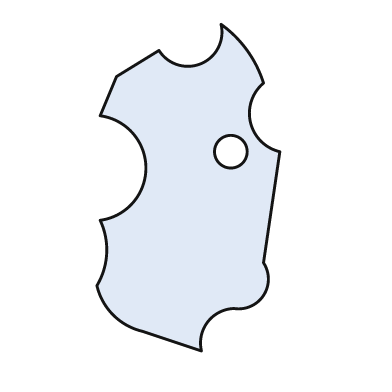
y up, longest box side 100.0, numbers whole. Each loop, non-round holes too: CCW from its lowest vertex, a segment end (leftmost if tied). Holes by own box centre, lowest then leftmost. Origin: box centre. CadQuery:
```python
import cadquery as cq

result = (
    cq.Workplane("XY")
    .moveTo(4.0, -50.0)
    .threePointArc((6.0, -41.0), (14.0, -37.0))
    .threePointArc((23.0, -33.0), (23.0, -23.0))
    .lineTo(28.0, 11.0)
    .threePointArc((19.0, 20.0), (23.0, 32.0))
    .threePointArc((18.0, 42.0), (10.0, 50.0))
    .threePointArc((4.0, 38.0), (-9.0, 42.0))
    .lineTo(-22.0, 34.0)
    .lineTo(-27.0, 22.0)
    .threePointArc((-13.0, 6.0), (-27.0, -10.0))
    .threePointArc((-25.0, -20.0), (-28.0, -30.0))
    .threePointArc((-23.0, -39.0), (-14.0, -44.0))
    .close()
    .moveTo(13.0, 11.0)
    .circle(5.0)
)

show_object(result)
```